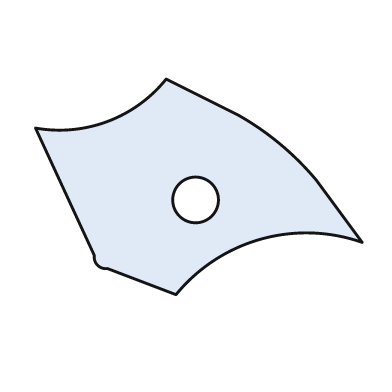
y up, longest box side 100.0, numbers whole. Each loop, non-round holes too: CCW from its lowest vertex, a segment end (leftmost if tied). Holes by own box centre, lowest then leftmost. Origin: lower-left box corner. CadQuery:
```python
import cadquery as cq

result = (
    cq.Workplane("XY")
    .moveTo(43.0, 0.0)
    .threePointArc((69.0, 17.0), (100.0, 16.0))
    .lineTo(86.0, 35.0)
    .threePointArc((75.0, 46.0), (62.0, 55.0))
    .lineTo(40.0, 66.0)
    .threePointArc((22.0, 53.0), (0.0, 51.0))
    .lineTo(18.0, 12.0)
    .threePointArc((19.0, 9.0), (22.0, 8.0))
    .close()
    .moveTo(49.0, 29.0)
    .circle(7.0)
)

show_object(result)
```